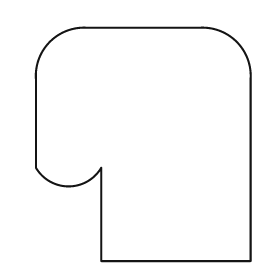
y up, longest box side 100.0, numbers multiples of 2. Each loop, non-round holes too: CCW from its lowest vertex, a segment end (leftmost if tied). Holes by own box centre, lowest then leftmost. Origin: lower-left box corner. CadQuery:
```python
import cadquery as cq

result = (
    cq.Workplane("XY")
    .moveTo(28.0, 0.0)
    .lineTo(92.0, 0.0)
    .lineTo(92.0, 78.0)
    .threePointArc((86.0, 94.0), (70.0, 100.0))
    .lineTo(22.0, 100.0)
    .threePointArc((6.0, 94.0), (0.0, 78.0))
    .lineTo(0.0, 40.0)
    .threePointArc((14.0, 32.0), (28.0, 40.0))
    .close()
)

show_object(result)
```